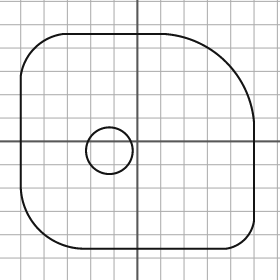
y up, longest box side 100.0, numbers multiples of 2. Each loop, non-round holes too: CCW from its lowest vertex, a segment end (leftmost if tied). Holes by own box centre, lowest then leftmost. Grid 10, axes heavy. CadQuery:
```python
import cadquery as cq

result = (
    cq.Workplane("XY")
    .moveTo(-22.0, -46.0)
    .lineTo(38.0, -46.0)
    .threePointArc((46.0, -42.0), (50.0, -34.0))
    .lineTo(50.0, 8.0)
    .threePointArc((38.0, 34.0), (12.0, 46.0))
    .lineTo(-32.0, 46.0)
    .threePointArc((-44.0, 40.0), (-50.0, 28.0))
    .lineTo(-50.0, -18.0)
    .threePointArc((-42.0, -38.0), (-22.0, -46.0))
    .close()
    .moveTo(-12.0, -4.0)
    .circle(10.0)
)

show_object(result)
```